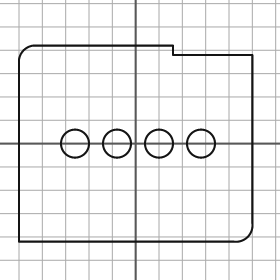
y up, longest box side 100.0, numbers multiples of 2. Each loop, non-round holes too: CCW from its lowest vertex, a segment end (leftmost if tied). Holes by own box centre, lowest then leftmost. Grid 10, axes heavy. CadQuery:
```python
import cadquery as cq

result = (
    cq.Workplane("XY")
    .moveTo(-50.0, -42.0)
    .lineTo(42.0, -42.0)
    .threePointArc((48.0, -40.0), (50.0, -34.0))
    .lineTo(50.0, 38.0)
    .lineTo(16.0, 38.0)
    .lineTo(16.0, 42.0)
    .lineTo(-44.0, 42.0)
    .threePointArc((-48.0, 40.0), (-50.0, 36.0))
    .close()
    .moveTo(-26.0, 0.0)
    .circle(6.0)
    .moveTo(-8.0, 0.0)
    .circle(6.0)
    .moveTo(10.0, 0.0)
    .circle(6.0)
    .moveTo(28.0, 0.0)
    .circle(6.0)
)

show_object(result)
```